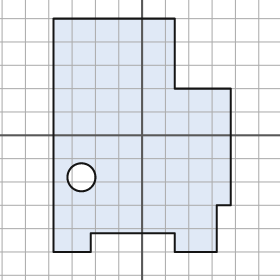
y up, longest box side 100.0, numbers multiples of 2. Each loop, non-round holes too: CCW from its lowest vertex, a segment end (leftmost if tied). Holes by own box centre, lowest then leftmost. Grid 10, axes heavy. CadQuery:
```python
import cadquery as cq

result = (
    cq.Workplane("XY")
    .moveTo(-38.0, -50.0)
    .lineTo(-22.0, -50.0)
    .lineTo(-22.0, -42.0)
    .lineTo(14.0, -42.0)
    .lineTo(14.0, -50.0)
    .lineTo(32.0, -50.0)
    .lineTo(32.0, -30.0)
    .lineTo(38.0, -30.0)
    .lineTo(38.0, 20.0)
    .lineTo(14.0, 20.0)
    .lineTo(14.0, 50.0)
    .lineTo(-38.0, 50.0)
    .close()
    .moveTo(-26.0, -18.0)
    .circle(6.0)
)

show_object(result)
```